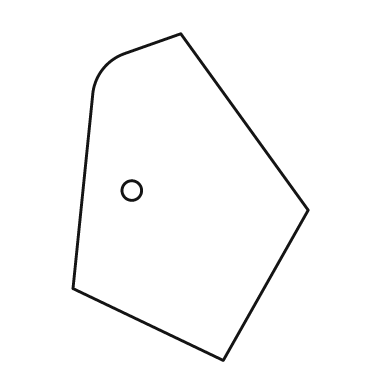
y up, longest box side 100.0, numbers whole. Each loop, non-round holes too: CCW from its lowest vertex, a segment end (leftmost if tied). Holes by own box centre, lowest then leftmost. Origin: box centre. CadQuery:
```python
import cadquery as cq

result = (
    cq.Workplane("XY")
    .moveTo(10.0, -50.0)
    .lineTo(36.0, -4.0)
    .lineTo(-3.0, 50.0)
    .lineTo(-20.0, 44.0)
    .threePointArc((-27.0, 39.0), (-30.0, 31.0))
    .lineTo(-36.0, -28.0)
    .close()
    .moveTo(-18.0, 2.0)
    .circle(3.0)
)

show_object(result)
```